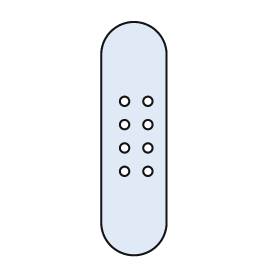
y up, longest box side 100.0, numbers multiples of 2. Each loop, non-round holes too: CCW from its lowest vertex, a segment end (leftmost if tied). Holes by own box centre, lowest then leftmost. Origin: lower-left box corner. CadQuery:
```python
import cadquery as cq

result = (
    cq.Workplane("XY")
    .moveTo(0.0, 14.0)
    .threePointArc((14.0, 0.0), (28.0, 14.0))
    .lineTo(28.0, 86.0)
    .threePointArc((14.0, 100.0), (0.0, 86.0))
    .close()
    .moveTo(10.0, 36.0)
    .circle(2.0)
    .moveTo(20.0, 36.0)
    .circle(2.0)
    .moveTo(10.0, 46.0)
    .circle(2.0)
    .moveTo(20.0, 46.0)
    .circle(2.0)
    .moveTo(10.0, 56.0)
    .circle(2.0)
    .moveTo(20.0, 56.0)
    .circle(2.0)
    .moveTo(10.0, 66.0)
    .circle(2.0)
    .moveTo(20.0, 66.0)
    .circle(2.0)
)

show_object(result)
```